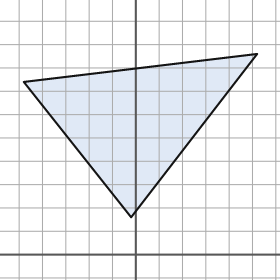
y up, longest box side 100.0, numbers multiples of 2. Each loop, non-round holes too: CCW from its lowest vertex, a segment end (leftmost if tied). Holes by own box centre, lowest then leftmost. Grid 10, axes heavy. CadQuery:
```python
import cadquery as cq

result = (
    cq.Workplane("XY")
    .moveTo(-2.0, 16.0)
    .lineTo(52.0, 86.0)
    .lineTo(-48.0, 74.0)
    .close()
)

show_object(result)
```